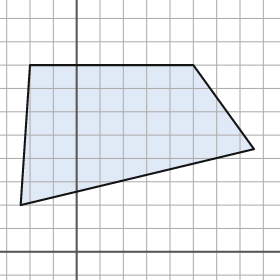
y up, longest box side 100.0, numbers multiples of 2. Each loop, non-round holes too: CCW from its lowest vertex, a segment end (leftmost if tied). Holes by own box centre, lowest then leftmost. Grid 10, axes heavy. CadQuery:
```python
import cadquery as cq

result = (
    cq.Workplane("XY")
    .moveTo(-24.0, 20.0)
    .lineTo(76.0, 44.0)
    .lineTo(50.0, 80.0)
    .lineTo(-20.0, 80.0)
    .close()
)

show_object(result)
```